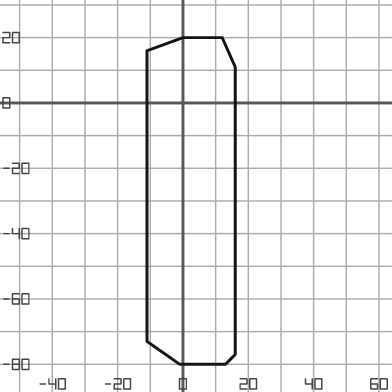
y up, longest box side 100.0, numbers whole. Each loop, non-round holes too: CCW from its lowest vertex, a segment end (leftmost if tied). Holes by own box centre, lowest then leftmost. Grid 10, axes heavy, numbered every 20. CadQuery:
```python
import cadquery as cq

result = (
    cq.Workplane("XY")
    .moveTo(-1.0, -80.0)
    .lineTo(13.0, -80.0)
    .lineTo(16.0, -77.0)
    .lineTo(16.0, 11.0)
    .lineTo(12.0, 20.0)
    .lineTo(0.0, 20.0)
    .lineTo(-11.0, 16.0)
    .lineTo(-11.0, -73.0)
    .close()
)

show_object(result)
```